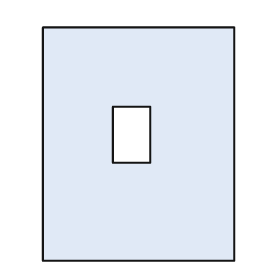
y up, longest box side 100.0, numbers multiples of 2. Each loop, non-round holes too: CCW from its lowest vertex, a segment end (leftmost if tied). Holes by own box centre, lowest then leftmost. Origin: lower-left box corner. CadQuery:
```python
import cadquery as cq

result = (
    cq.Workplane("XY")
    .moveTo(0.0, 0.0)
    .lineTo(82.0, 0.0)
    .lineTo(82.0, 100.0)
    .lineTo(0.0, 100.0)
    .close()
    .moveTo(30.0, 42.0)
    .lineTo(46.0, 42.0)
    .lineTo(46.0, 66.0)
    .lineTo(30.0, 66.0)
    .close()
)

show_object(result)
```